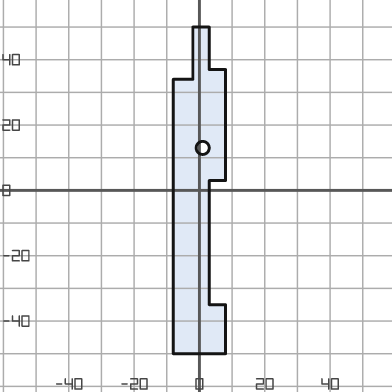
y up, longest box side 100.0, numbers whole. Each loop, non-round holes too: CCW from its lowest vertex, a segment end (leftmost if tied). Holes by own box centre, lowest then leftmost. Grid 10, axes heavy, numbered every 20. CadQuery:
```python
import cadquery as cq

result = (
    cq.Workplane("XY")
    .moveTo(-8.0, -50.0)
    .lineTo(8.0, -50.0)
    .lineTo(8.0, -35.0)
    .lineTo(3.0, -35.0)
    .lineTo(3.0, 3.0)
    .lineTo(8.0, 3.0)
    .lineTo(8.0, 37.0)
    .lineTo(3.0, 37.0)
    .lineTo(3.0, 50.0)
    .lineTo(-2.0, 50.0)
    .lineTo(-2.0, 34.0)
    .lineTo(-8.0, 34.0)
    .close()
    .moveTo(1.0, 13.0)
    .circle(2.0)
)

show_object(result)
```